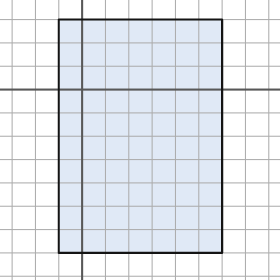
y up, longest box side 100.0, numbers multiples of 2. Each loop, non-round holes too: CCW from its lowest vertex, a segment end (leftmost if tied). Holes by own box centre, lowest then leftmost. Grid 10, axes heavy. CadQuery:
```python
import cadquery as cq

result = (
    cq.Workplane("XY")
    .moveTo(-10.0, -70.0)
    .lineTo(60.0, -70.0)
    .lineTo(60.0, 30.0)
    .lineTo(-10.0, 30.0)
    .close()
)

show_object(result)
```